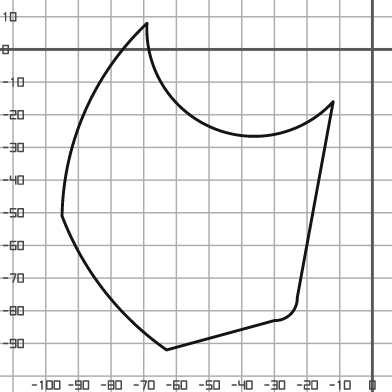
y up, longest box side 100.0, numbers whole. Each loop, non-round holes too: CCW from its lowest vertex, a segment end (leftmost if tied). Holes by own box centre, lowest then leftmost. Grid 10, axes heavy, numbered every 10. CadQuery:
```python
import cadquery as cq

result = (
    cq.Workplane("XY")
    .moveTo(-63.0, -92.0)
    .lineTo(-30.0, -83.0)
    .threePointArc((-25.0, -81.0), (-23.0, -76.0))
    .lineTo(-12.0, -16.0)
    .threePointArc((-49.0, -24.0), (-69.0, 8.0))
    .threePointArc((-88.0, -19.0), (-95.0, -51.0))
    .threePointArc((-82.0, -74.0), (-63.0, -92.0))
    .close()
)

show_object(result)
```